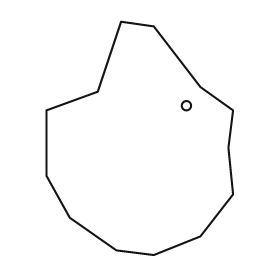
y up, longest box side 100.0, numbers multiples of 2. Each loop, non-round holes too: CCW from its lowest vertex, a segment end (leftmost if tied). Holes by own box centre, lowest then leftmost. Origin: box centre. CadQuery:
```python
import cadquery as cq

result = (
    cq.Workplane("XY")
    .moveTo(6.0, -50.0)
    .lineTo(26.0, -42.0)
    .lineTo(40.0, -24.0)
    .lineTo(38.0, -4.0)
    .lineTo(40.0, 12.0)
    .lineTo(26.0, 22.0)
    .lineTo(6.0, 48.0)
    .lineTo(-8.0, 50.0)
    .lineTo(-18.0, 20.0)
    .lineTo(-40.0, 12.0)
    .lineTo(-40.0, -16.0)
    .lineTo(-30.0, -34.0)
    .lineTo(-10.0, -48.0)
    .close()
    .moveTo(20.0, 14.0)
    .circle(2.0)
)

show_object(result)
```